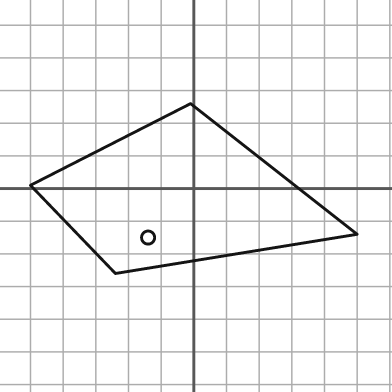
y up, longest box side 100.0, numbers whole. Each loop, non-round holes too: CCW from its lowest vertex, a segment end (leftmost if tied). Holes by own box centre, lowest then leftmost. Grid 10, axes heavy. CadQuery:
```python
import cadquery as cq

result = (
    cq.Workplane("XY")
    .moveTo(-24.0, -26.0)
    .lineTo(50.0, -14.0)
    .lineTo(-1.0, 26.0)
    .lineTo(-50.0, 1.0)
    .close()
    .moveTo(-14.0, -15.0)
    .circle(2.0)
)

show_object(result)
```